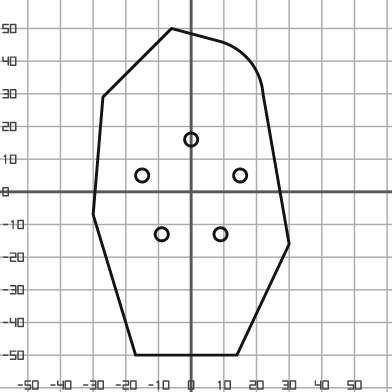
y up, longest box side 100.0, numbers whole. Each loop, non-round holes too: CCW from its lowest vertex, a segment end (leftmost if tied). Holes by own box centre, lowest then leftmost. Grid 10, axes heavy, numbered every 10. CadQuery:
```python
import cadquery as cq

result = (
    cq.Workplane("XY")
    .moveTo(-17.0, -50.0)
    .lineTo(14.0, -50.0)
    .lineTo(30.0, -16.0)
    .lineTo(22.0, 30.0)
    .threePointArc((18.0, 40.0), (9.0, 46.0))
    .lineTo(-6.0, 50.0)
    .lineTo(-27.0, 29.0)
    .lineTo(-30.0, -7.0)
    .close()
    .moveTo(-9.0, -13.0)
    .circle(2.0)
    .moveTo(9.0, -13.0)
    .circle(2.0)
    .moveTo(-15.0, 5.0)
    .circle(2.0)
    .moveTo(15.0, 5.0)
    .circle(2.0)
    .moveTo(0.0, 16.0)
    .circle(2.0)
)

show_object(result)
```